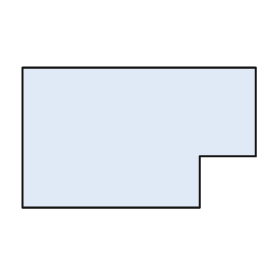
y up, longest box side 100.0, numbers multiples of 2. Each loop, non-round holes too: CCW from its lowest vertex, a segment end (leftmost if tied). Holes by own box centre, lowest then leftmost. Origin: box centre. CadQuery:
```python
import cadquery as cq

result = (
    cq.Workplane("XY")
    .moveTo(-50.0, -30.0)
    .lineTo(26.0, -30.0)
    .lineTo(26.0, -8.0)
    .lineTo(50.0, -8.0)
    .lineTo(50.0, 30.0)
    .lineTo(-50.0, 30.0)
    .close()
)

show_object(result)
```